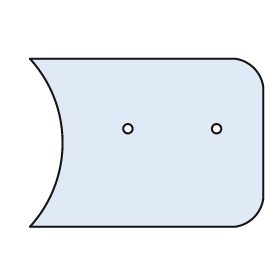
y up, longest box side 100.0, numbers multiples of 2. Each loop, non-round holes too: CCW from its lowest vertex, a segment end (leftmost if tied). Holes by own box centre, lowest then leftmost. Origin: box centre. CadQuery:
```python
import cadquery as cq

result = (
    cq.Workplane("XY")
    .moveTo(-50.0, -36.0)
    .lineTo(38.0, -36.0)
    .threePointArc((46.0, -32.0), (50.0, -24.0))
    .lineTo(50.0, 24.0)
    .threePointArc((46.0, 32.0), (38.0, 36.0))
    .lineTo(-50.0, 36.0)
    .threePointArc((-36.0, 0.0), (-50.0, -36.0))
    .close()
    .moveTo(-8.0, 6.0)
    .circle(2.0)
    .moveTo(30.0, 6.0)
    .circle(2.0)
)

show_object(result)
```